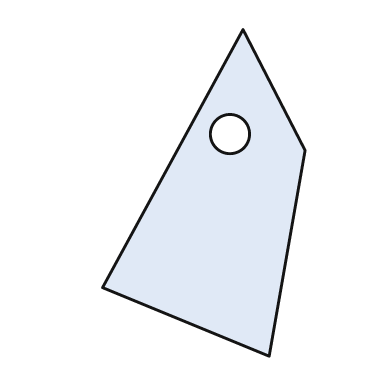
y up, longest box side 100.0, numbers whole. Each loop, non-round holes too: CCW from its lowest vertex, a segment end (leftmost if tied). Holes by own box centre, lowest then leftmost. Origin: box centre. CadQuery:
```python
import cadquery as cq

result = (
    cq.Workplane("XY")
    .moveTo(20.0, -50.0)
    .lineTo(31.0, 13.0)
    .lineTo(12.0, 50.0)
    .lineTo(-31.0, -29.0)
    .close()
    .moveTo(8.0, 18.0)
    .circle(6.0)
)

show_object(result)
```